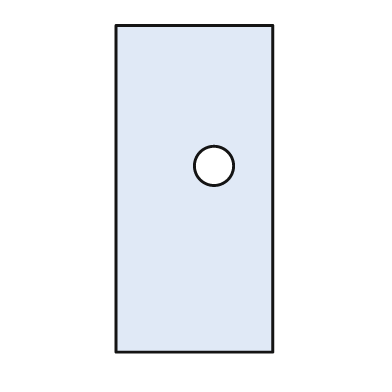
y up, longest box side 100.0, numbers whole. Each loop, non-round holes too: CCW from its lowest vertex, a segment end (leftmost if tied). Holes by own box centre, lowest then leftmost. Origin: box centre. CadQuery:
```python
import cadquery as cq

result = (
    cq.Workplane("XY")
    .moveTo(-24.0, -50.0)
    .lineTo(24.0, -50.0)
    .lineTo(24.0, 50.0)
    .lineTo(-24.0, 50.0)
    .close()
    .moveTo(6.0, 7.0)
    .circle(6.0)
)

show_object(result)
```